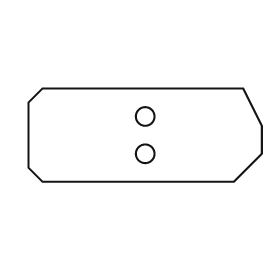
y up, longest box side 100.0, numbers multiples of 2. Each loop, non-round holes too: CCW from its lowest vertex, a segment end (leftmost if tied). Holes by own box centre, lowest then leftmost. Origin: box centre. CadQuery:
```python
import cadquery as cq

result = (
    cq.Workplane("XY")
    .moveTo(-44.0, -20.0)
    .lineTo(38.0, -20.0)
    .lineTo(50.0, -8.0)
    .lineTo(50.0, 4.0)
    .lineTo(42.0, 20.0)
    .lineTo(-44.0, 20.0)
    .lineTo(-50.0, 14.0)
    .lineTo(-50.0, -14.0)
    .close()
    .moveTo(0.0, -8.0)
    .circle(4.0)
    .moveTo(0.0, 8.0)
    .circle(4.0)
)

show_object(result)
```